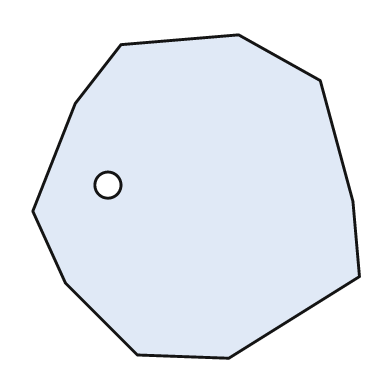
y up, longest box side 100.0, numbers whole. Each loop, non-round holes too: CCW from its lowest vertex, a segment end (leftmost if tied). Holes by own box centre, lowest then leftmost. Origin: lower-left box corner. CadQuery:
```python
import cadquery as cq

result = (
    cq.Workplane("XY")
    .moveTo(60.0, 0.0)
    .lineTo(100.0, 25.0)
    .lineTo(98.0, 48.0)
    .lineTo(88.0, 85.0)
    .lineTo(63.0, 99.0)
    .lineTo(27.0, 96.0)
    .lineTo(13.0, 78.0)
    .lineTo(0.0, 45.0)
    .lineTo(10.0, 23.0)
    .lineTo(32.0, 1.0)
    .close()
    .moveTo(23.0, 53.0)
    .circle(4.0)
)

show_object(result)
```